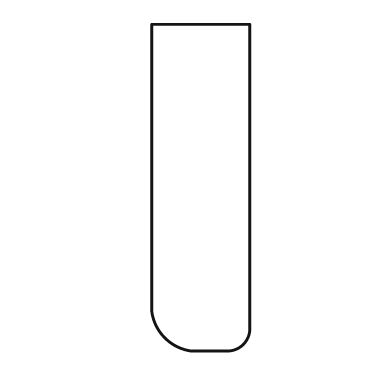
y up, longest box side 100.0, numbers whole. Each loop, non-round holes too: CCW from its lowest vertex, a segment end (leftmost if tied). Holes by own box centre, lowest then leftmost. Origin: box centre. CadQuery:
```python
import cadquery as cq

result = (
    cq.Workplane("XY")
    .moveTo(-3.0, -50.0)
    .lineTo(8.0, -50.0)
    .threePointArc((13.0, -48.0), (15.0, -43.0))
    .lineTo(15.0, 50.0)
    .lineTo(-15.0, 50.0)
    .lineTo(-15.0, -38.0)
    .threePointArc((-11.0, -46.0), (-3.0, -50.0))
    .close()
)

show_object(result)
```